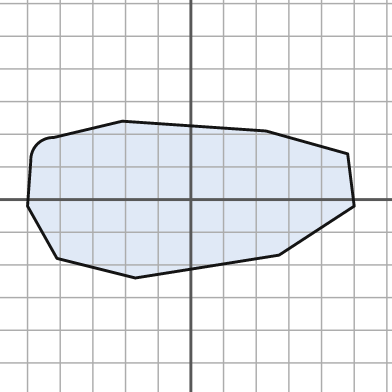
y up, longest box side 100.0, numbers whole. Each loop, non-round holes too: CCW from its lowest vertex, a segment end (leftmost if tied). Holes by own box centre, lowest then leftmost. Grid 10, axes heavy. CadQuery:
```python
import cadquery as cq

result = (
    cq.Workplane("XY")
    .moveTo(-17.0, -24.0)
    .lineTo(27.0, -17.0)
    .lineTo(50.0, -2.0)
    .lineTo(48.0, 14.0)
    .lineTo(23.0, 21.0)
    .lineTo(-21.0, 24.0)
    .lineTo(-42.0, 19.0)
    .threePointArc((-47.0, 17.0), (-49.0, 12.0))
    .lineTo(-50.0, -2.0)
    .lineTo(-41.0, -18.0)
    .close()
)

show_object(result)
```